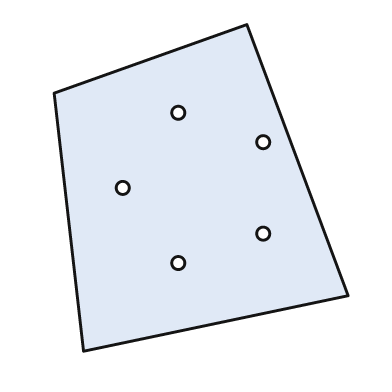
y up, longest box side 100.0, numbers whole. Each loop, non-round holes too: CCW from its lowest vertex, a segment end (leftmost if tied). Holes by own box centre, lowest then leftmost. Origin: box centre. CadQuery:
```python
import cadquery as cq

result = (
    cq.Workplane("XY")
    .moveTo(-36.0, -50.0)
    .lineTo(45.0, -33.0)
    .lineTo(14.0, 50.0)
    .lineTo(-45.0, 29.0)
    .close()
    .moveTo(-7.0, -23.0)
    .circle(2.0)
    .moveTo(19.0, -14.0)
    .circle(2.0)
    .moveTo(-24.0, 0.0)
    .circle(2.0)
    .moveTo(19.0, 14.0)
    .circle(2.0)
    .moveTo(-7.0, 23.0)
    .circle(2.0)
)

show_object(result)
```